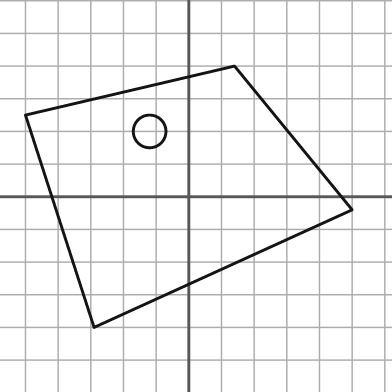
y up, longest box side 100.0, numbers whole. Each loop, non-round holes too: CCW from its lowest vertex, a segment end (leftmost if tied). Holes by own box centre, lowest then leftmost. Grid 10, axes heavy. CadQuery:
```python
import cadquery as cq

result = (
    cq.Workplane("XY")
    .moveTo(-29.0, -40.0)
    .lineTo(50.0, -4.0)
    .lineTo(14.0, 40.0)
    .lineTo(-50.0, 25.0)
    .close()
    .moveTo(-12.0, 20.0)
    .circle(5.0)
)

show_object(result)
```